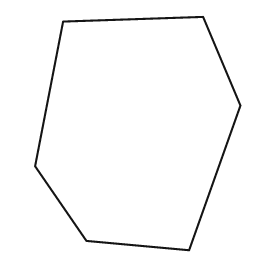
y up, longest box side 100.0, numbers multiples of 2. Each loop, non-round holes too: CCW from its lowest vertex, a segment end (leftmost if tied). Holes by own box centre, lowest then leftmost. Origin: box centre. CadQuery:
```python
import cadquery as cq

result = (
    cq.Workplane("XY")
    .moveTo(22.0, -50.0)
    .lineTo(44.0, 12.0)
    .lineTo(28.0, 50.0)
    .lineTo(-32.0, 48.0)
    .lineTo(-44.0, -14.0)
    .lineTo(-22.0, -46.0)
    .close()
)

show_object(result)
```